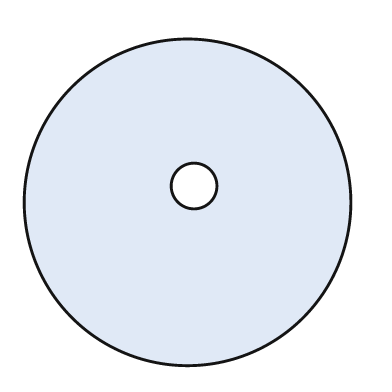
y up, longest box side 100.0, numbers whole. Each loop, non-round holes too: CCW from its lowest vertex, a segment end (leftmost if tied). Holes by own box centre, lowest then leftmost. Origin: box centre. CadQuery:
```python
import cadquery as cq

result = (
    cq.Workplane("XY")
    .moveTo(0.0, 0.0)
    .circle(50.0)
    .moveTo(2.0, 5.0)
    .circle(7.0)
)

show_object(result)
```